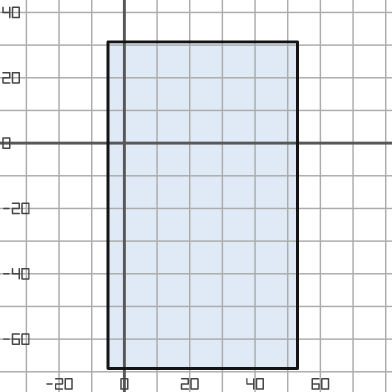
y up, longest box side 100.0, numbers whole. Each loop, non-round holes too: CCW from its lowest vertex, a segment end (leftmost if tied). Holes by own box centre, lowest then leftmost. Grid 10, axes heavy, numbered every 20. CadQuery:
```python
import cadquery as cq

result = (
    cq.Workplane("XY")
    .moveTo(-5.0, -69.0)
    .lineTo(53.0, -69.0)
    .lineTo(53.0, 31.0)
    .lineTo(-5.0, 31.0)
    .close()
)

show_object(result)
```